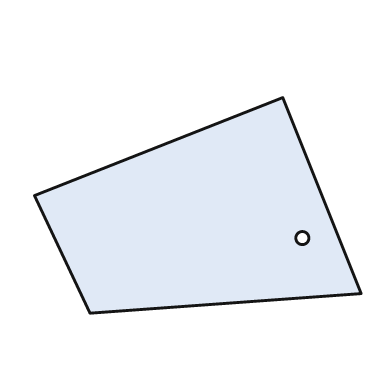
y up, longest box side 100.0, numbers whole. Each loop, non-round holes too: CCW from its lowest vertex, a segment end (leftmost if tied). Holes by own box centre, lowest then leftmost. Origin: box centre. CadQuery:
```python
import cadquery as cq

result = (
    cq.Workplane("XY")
    .moveTo(-33.0, -33.0)
    .lineTo(50.0, -27.0)
    .lineTo(26.0, 33.0)
    .lineTo(-50.0, 3.0)
    .close()
    .moveTo(32.0, -10.0)
    .circle(2.0)
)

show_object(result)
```